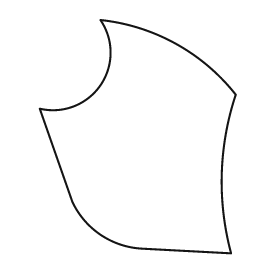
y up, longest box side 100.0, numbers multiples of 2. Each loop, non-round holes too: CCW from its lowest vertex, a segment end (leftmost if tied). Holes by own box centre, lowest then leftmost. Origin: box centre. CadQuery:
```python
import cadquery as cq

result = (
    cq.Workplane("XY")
    .moveTo(40.0, -50.0)
    .threePointArc((36.0, -16.0), (42.0, 18.0))
    .threePointArc((16.0, 40.0), (-16.0, 50.0))
    .threePointArc((-16.0, 22.0), (-42.0, 12.0))
    .lineTo(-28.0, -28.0)
    .threePointArc((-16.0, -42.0), (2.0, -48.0))
    .close()
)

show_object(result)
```